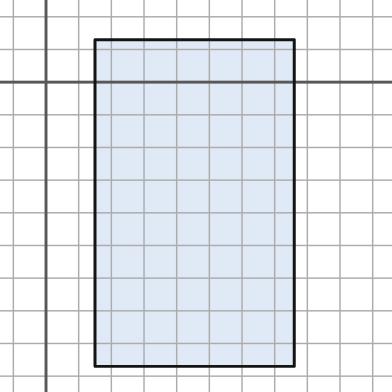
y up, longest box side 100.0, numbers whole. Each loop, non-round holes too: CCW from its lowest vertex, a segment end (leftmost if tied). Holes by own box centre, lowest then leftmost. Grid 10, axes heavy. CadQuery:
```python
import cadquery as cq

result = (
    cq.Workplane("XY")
    .moveTo(15.0, -87.0)
    .lineTo(76.0, -87.0)
    .lineTo(76.0, 13.0)
    .lineTo(15.0, 13.0)
    .close()
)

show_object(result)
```